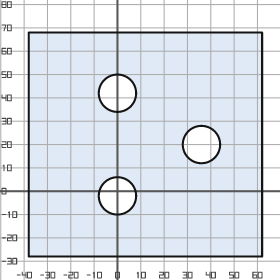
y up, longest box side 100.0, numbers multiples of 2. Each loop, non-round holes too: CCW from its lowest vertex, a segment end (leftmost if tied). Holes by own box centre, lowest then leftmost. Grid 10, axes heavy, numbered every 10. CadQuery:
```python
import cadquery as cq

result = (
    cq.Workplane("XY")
    .moveTo(-38.0, -28.0)
    .lineTo(62.0, -28.0)
    .lineTo(62.0, 68.0)
    .lineTo(-38.0, 68.0)
    .close()
    .moveTo(0.0, -2.0)
    .circle(8.0)
    .moveTo(36.0, 20.0)
    .circle(8.0)
    .moveTo(0.0, 42.0)
    .circle(8.0)
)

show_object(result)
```